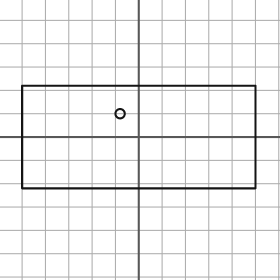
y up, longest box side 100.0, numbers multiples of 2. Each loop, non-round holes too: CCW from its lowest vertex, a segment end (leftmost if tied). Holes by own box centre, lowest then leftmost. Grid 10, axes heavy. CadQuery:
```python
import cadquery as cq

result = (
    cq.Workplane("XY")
    .moveTo(-50.0, -22.0)
    .lineTo(50.0, -22.0)
    .lineTo(50.0, 22.0)
    .lineTo(-50.0, 22.0)
    .close()
    .moveTo(-8.0, 10.0)
    .circle(2.0)
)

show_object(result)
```